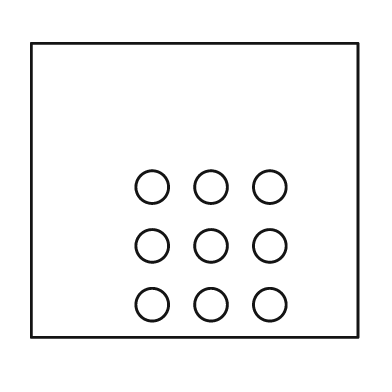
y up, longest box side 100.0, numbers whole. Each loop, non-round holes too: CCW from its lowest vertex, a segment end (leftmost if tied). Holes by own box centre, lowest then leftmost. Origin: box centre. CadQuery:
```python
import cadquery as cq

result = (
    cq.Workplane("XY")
    .moveTo(-50.0, -45.0)
    .lineTo(50.0, -45.0)
    .lineTo(50.0, 45.0)
    .lineTo(-50.0, 45.0)
    .close()
    .moveTo(-13.0, -35.0)
    .circle(5.0)
    .moveTo(5.0, -35.0)
    .circle(5.0)
    .moveTo(23.0, -35.0)
    .circle(5.0)
    .moveTo(-13.0, -17.0)
    .circle(5.0)
    .moveTo(5.0, -17.0)
    .circle(5.0)
    .moveTo(23.0, -17.0)
    .circle(5.0)
    .moveTo(-13.0, 1.0)
    .circle(5.0)
    .moveTo(5.0, 1.0)
    .circle(5.0)
    .moveTo(23.0, 1.0)
    .circle(5.0)
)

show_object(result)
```